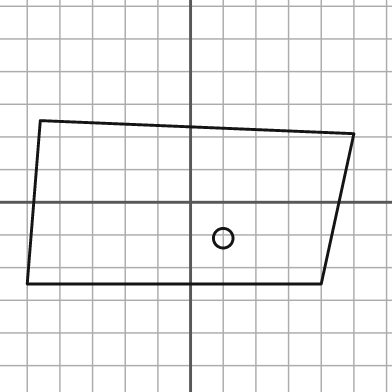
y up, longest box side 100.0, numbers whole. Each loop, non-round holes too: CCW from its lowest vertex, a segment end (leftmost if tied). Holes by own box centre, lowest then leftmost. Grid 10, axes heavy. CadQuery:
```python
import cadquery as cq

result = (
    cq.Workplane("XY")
    .moveTo(-50.0, -25.0)
    .lineTo(40.0, -25.0)
    .lineTo(50.0, 21.0)
    .lineTo(-46.0, 25.0)
    .close()
    .moveTo(10.0, -11.0)
    .circle(3.0)
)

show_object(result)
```